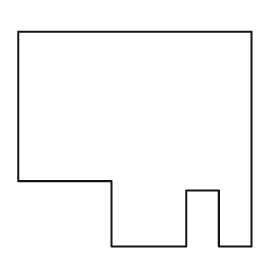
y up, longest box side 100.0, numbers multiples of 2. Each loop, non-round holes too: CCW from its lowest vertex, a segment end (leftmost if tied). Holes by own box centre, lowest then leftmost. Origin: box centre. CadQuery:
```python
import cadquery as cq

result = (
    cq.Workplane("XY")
    .moveTo(-10.0, -46.0)
    .lineTo(22.0, -46.0)
    .lineTo(22.0, -22.0)
    .lineTo(36.0, -22.0)
    .lineTo(36.0, -46.0)
    .lineTo(50.0, -46.0)
    .lineTo(50.0, 46.0)
    .lineTo(-50.0, 46.0)
    .lineTo(-50.0, -18.0)
    .lineTo(-10.0, -18.0)
    .close()
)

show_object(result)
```